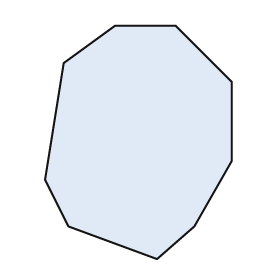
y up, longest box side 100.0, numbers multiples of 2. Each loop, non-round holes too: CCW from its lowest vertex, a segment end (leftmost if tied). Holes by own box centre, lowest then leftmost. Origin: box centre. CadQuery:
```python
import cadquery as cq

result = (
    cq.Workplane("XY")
    .moveTo(8.0, -50.0)
    .lineTo(24.0, -36.0)
    .lineTo(40.0, -8.0)
    .lineTo(40.0, 26.0)
    .lineTo(16.0, 50.0)
    .lineTo(-10.0, 50.0)
    .lineTo(-32.0, 34.0)
    .lineTo(-40.0, -16.0)
    .lineTo(-30.0, -36.0)
    .close()
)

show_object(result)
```